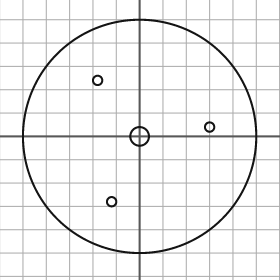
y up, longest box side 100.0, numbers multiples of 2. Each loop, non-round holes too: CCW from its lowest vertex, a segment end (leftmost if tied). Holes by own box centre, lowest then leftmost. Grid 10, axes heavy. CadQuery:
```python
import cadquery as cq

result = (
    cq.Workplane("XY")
    .moveTo(0.0, 0.0)
    .circle(50.0)
    .moveTo(-12.0, -28.0)
    .circle(2.0)
    .moveTo(0.0, 0.0)
    .circle(4.0)
    .moveTo(30.0, 4.0)
    .circle(2.0)
    .moveTo(-18.0, 24.0)
    .circle(2.0)
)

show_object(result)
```